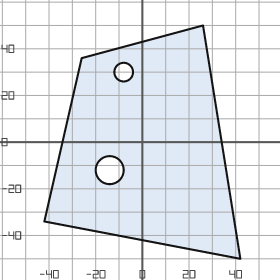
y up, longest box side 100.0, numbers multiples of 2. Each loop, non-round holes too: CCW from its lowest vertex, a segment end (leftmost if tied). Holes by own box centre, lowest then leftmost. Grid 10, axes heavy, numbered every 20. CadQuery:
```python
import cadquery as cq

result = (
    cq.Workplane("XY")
    .moveTo(42.0, -50.0)
    .lineTo(26.0, 50.0)
    .lineTo(-26.0, 36.0)
    .lineTo(-42.0, -34.0)
    .close()
    .moveTo(-14.0, -12.0)
    .circle(6.0)
    .moveTo(-8.0, 30.0)
    .circle(4.0)
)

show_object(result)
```